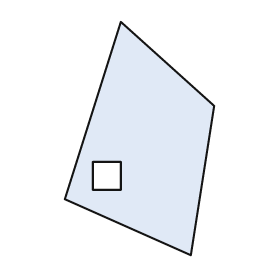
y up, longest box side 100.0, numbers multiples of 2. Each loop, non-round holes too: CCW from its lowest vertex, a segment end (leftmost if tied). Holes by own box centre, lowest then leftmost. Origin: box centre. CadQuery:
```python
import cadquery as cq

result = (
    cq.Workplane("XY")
    .moveTo(22.0, -50.0)
    .lineTo(32.0, 14.0)
    .lineTo(-8.0, 50.0)
    .lineTo(-32.0, -26.0)
    .close()
    .moveTo(-20.0, -22.0)
    .lineTo(-8.0, -22.0)
    .lineTo(-8.0, -10.0)
    .lineTo(-20.0, -10.0)
    .close()
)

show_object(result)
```